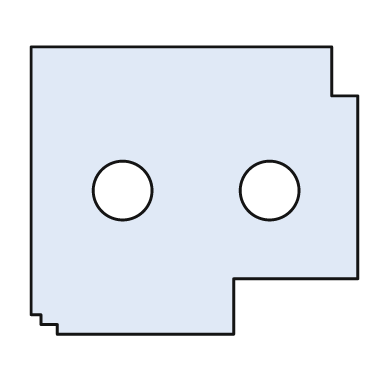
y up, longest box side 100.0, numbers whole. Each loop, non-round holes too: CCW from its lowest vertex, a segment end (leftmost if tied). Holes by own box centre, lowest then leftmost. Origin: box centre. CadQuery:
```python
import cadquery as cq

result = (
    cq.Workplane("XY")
    .moveTo(-42.0, -44.0)
    .lineTo(12.0, -44.0)
    .lineTo(12.0, -27.0)
    .lineTo(50.0, -27.0)
    .lineTo(50.0, 29.0)
    .lineTo(42.0, 29.0)
    .lineTo(42.0, 44.0)
    .lineTo(-50.0, 44.0)
    .lineTo(-50.0, -38.0)
    .lineTo(-47.0, -38.0)
    .lineTo(-47.0, -41.0)
    .lineTo(-42.0, -41.0)
    .close()
    .moveTo(-22.0, 0.0)
    .circle(9.0)
    .moveTo(23.0, 0.0)
    .circle(9.0)
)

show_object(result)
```